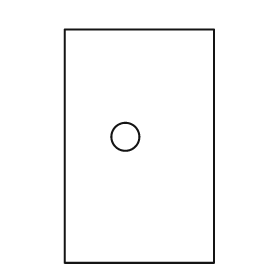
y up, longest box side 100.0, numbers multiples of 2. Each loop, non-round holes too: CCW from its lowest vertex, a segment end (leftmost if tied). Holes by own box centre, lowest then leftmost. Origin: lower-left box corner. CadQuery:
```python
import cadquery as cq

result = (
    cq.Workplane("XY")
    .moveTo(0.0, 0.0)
    .lineTo(64.0, 0.0)
    .lineTo(64.0, 100.0)
    .lineTo(0.0, 100.0)
    .close()
    .moveTo(26.0, 54.0)
    .circle(6.0)
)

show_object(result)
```